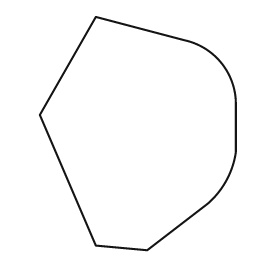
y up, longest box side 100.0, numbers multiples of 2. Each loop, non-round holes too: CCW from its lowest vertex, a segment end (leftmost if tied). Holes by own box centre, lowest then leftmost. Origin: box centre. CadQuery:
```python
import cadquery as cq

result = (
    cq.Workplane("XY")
    .moveTo(4.0, -50.0)
    .lineTo(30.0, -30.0)
    .threePointArc((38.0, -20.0), (42.0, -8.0))
    .lineTo(42.0, 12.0)
    .threePointArc((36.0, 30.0), (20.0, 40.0))
    .lineTo(-18.0, 50.0)
    .lineTo(-42.0, 8.0)
    .lineTo(-18.0, -48.0)
    .close()
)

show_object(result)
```